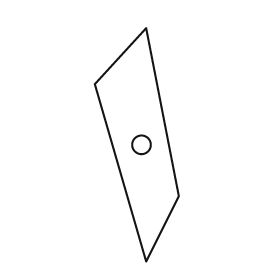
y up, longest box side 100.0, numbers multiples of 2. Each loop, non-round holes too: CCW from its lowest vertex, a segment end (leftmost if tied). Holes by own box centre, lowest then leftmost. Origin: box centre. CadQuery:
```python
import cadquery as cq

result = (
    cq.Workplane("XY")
    .moveTo(4.0, -50.0)
    .lineTo(18.0, -22.0)
    .lineTo(4.0, 50.0)
    .lineTo(-18.0, 26.0)
    .close()
    .moveTo(2.0, 0.0)
    .circle(4.0)
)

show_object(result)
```